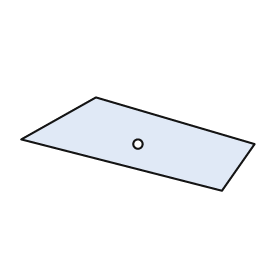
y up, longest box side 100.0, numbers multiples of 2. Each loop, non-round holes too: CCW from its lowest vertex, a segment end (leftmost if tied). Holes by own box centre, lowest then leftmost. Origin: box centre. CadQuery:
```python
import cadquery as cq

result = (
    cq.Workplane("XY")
    .moveTo(36.0, -20.0)
    .lineTo(50.0, 0.0)
    .lineTo(-18.0, 20.0)
    .lineTo(-50.0, 2.0)
    .close()
    .moveTo(0.0, 0.0)
    .circle(2.0)
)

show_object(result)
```